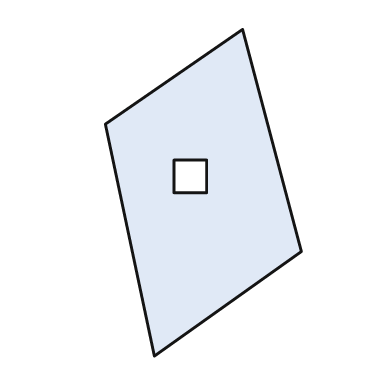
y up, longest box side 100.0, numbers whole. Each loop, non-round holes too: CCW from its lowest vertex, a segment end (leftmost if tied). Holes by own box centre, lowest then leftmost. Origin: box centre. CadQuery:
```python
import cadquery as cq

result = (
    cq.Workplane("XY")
    .moveTo(-15.0, -50.0)
    .lineTo(30.0, -18.0)
    .lineTo(12.0, 50.0)
    .lineTo(-30.0, 21.0)
    .close()
    .moveTo(-9.0, 0.0)
    .lineTo(1.0, 0.0)
    .lineTo(1.0, 10.0)
    .lineTo(-9.0, 10.0)
    .close()
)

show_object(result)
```